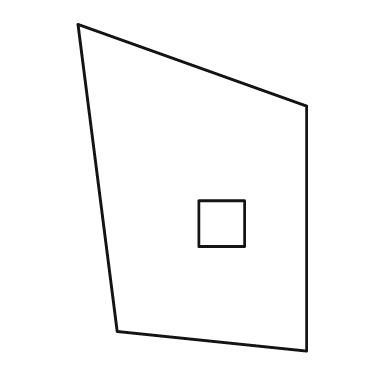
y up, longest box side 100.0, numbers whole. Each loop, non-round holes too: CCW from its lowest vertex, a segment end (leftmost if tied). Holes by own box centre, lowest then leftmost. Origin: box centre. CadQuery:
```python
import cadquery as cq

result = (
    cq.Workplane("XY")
    .moveTo(35.0, -50.0)
    .lineTo(35.0, 25.0)
    .lineTo(-35.0, 50.0)
    .lineTo(-23.0, -44.0)
    .close()
    .moveTo(2.0, -18.0)
    .lineTo(16.0, -18.0)
    .lineTo(16.0, -4.0)
    .lineTo(2.0, -4.0)
    .close()
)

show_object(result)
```